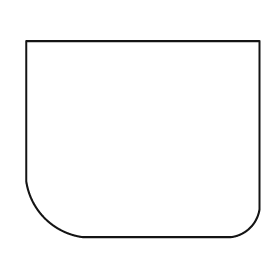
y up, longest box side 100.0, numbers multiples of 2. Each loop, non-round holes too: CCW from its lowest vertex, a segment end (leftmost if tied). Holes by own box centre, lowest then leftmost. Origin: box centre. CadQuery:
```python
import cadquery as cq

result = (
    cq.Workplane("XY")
    .moveTo(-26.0, -42.0)
    .lineTo(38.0, -42.0)
    .threePointArc((46.0, -38.0), (50.0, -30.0))
    .lineTo(50.0, 42.0)
    .lineTo(-50.0, 42.0)
    .lineTo(-50.0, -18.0)
    .threePointArc((-42.0, -34.0), (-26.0, -42.0))
    .close()
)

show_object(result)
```